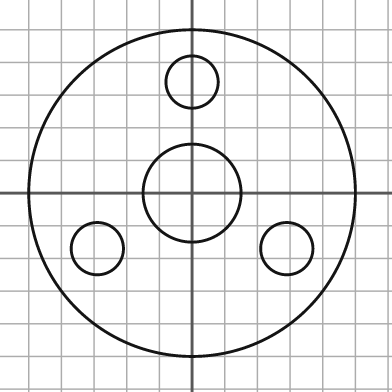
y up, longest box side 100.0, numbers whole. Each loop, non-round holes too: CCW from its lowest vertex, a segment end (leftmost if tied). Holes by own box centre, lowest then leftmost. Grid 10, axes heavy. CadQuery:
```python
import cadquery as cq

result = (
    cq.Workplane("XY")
    .moveTo(0.0, 0.0)
    .circle(50.0)
    .moveTo(-29.0, -17.0)
    .circle(8.0)
    .moveTo(29.0, -17.0)
    .circle(8.0)
    .moveTo(0.0, 0.0)
    .circle(15.0)
    .moveTo(0.0, 34.0)
    .circle(8.0)
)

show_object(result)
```